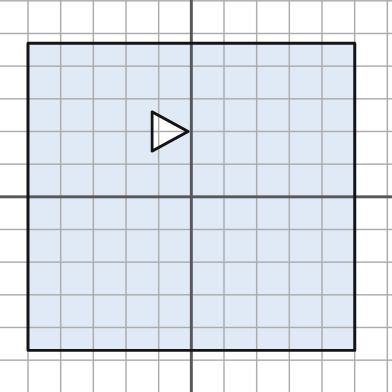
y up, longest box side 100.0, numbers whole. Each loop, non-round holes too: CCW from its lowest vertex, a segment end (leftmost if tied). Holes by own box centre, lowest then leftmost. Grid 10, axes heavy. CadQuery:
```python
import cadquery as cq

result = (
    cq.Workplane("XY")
    .moveTo(-50.0, -47.0)
    .lineTo(50.0, -47.0)
    .lineTo(50.0, 47.0)
    .lineTo(-50.0, 47.0)
    .close()
    .moveTo(-12.0, 14.0)
    .lineTo(-1.0, 20.0)
    .lineTo(-12.0, 26.0)
    .close()
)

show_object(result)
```